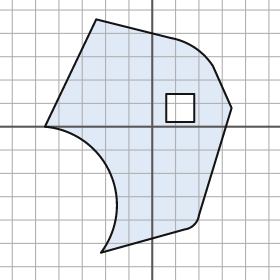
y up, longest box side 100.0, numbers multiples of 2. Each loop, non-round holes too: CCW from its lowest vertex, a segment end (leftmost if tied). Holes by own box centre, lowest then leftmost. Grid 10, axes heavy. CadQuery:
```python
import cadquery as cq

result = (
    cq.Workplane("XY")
    .moveTo(-22.0, -54.0)
    .lineTo(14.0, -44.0)
    .threePointArc((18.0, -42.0), (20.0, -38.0))
    .lineTo(34.0, 8.0)
    .lineTo(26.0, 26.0)
    .threePointArc((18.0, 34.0), (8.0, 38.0))
    .lineTo(-24.0, 46.0)
    .lineTo(-46.0, 0.0)
    .threePointArc((-18.0, -20.0), (-22.0, -54.0))
    .close()
    .moveTo(6.0, 2.0)
    .lineTo(18.0, 2.0)
    .lineTo(18.0, 14.0)
    .lineTo(6.0, 14.0)
    .close()
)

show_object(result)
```